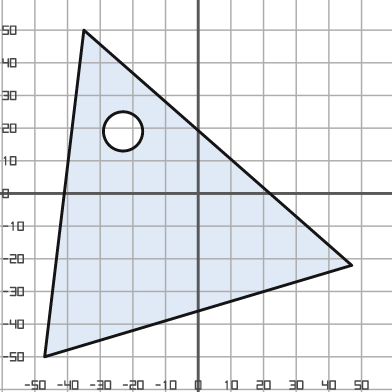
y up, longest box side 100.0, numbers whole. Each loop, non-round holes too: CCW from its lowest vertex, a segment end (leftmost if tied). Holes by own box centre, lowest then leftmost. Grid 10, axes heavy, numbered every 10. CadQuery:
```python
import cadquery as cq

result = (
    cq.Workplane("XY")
    .moveTo(-47.0, -50.0)
    .lineTo(47.0, -22.0)
    .lineTo(-35.0, 50.0)
    .close()
    .moveTo(-23.0, 19.0)
    .circle(6.0)
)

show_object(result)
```